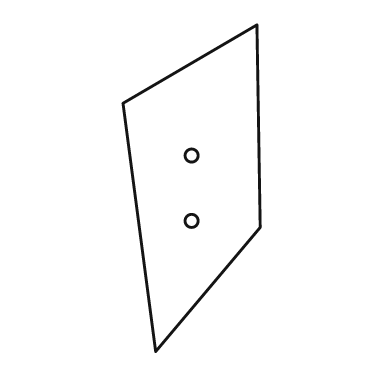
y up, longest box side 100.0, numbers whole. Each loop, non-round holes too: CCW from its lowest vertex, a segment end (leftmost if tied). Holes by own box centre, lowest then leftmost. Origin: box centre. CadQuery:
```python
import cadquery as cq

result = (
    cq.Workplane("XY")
    .moveTo(-11.0, -50.0)
    .lineTo(21.0, -12.0)
    .lineTo(20.0, 50.0)
    .lineTo(-21.0, 26.0)
    .close()
    .moveTo(0.0, -10.0)
    .circle(2.0)
    .moveTo(0.0, 10.0)
    .circle(2.0)
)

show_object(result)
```